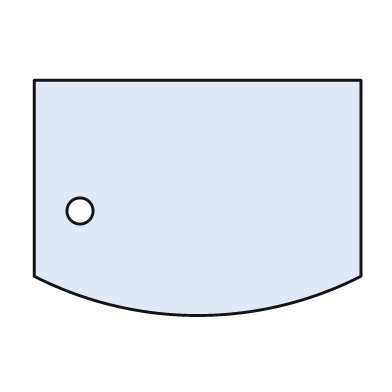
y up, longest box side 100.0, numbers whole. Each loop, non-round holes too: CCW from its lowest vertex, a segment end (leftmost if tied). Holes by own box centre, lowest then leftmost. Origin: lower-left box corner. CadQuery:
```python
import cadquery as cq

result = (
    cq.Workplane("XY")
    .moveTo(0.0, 12.0)
    .threePointArc((50.0, 0.0), (100.0, 12.0))
    .lineTo(100.0, 72.0)
    .lineTo(0.0, 72.0)
    .close()
    .moveTo(14.0, 32.0)
    .circle(4.0)
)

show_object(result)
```